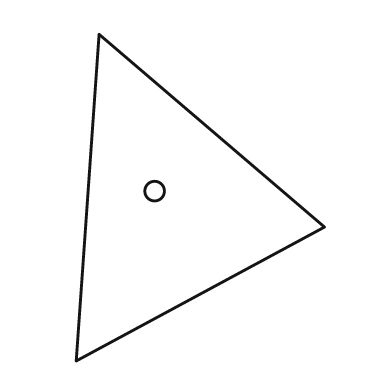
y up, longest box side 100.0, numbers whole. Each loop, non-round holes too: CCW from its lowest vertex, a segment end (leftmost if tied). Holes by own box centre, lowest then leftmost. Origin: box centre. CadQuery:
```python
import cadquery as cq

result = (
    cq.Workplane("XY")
    .moveTo(-38.0, -50.0)
    .lineTo(38.0, -9.0)
    .lineTo(-31.0, 50.0)
    .close()
    .moveTo(-14.0, 2.0)
    .circle(3.0)
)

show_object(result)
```